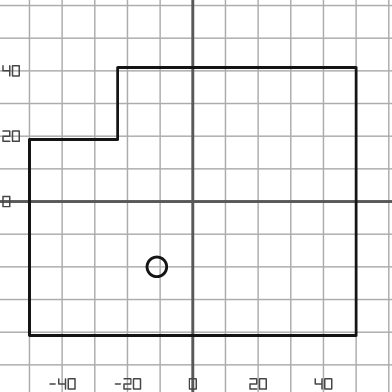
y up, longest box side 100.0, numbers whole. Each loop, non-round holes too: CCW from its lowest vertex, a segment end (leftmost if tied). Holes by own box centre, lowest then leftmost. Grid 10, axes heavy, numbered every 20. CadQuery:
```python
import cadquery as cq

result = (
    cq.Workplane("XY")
    .moveTo(-50.0, -41.0)
    .lineTo(50.0, -41.0)
    .lineTo(50.0, 41.0)
    .lineTo(-23.0, 41.0)
    .lineTo(-23.0, 19.0)
    .lineTo(-50.0, 19.0)
    .close()
    .moveTo(-11.0, -20.0)
    .circle(3.0)
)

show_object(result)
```